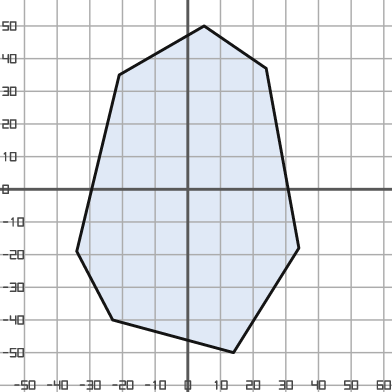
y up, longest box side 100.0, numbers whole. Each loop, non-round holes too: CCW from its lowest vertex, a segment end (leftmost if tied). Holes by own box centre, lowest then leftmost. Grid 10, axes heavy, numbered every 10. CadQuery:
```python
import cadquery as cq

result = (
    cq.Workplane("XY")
    .moveTo(14.0, -50.0)
    .lineTo(34.0, -18.0)
    .lineTo(24.0, 37.0)
    .lineTo(5.0, 50.0)
    .lineTo(-21.0, 35.0)
    .lineTo(-34.0, -19.0)
    .lineTo(-23.0, -40.0)
    .close()
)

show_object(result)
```